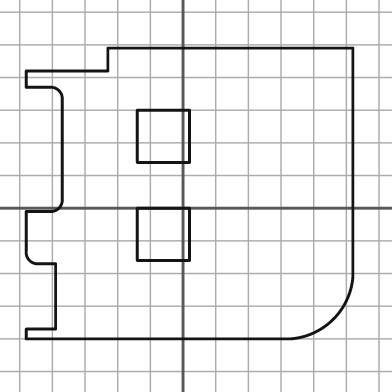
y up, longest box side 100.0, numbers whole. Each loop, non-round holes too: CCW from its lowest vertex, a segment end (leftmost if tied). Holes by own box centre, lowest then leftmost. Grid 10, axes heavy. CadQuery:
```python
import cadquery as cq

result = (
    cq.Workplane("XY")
    .moveTo(-48.0, -40.0)
    .lineTo(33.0, -40.0)
    .threePointArc((46.0, -34.0), (52.0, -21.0))
    .lineTo(52.0, 49.0)
    .lineTo(-23.0, 49.0)
    .lineTo(-23.0, 42.0)
    .lineTo(-48.0, 42.0)
    .lineTo(-48.0, 37.0)
    .lineTo(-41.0, 37.0)
    .threePointArc((-38.0, 36.0), (-37.0, 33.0))
    .lineTo(-37.0, 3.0)
    .threePointArc((-38.0, 0.0), (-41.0, -1.0))
    .lineTo(-48.0, -1.0)
    .lineTo(-48.0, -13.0)
    .threePointArc((-47.0, -16.0), (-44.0, -17.0))
    .lineTo(-39.0, -17.0)
    .lineTo(-39.0, -37.0)
    .lineTo(-48.0, -37.0)
    .close()
    .moveTo(-14.0, -16.0)
    .lineTo(2.0, -16.0)
    .lineTo(2.0, 0.0)
    .lineTo(-14.0, 0.0)
    .close()
    .moveTo(-14.0, 14.0)
    .lineTo(2.0, 14.0)
    .lineTo(2.0, 30.0)
    .lineTo(-14.0, 30.0)
    .close()
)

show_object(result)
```